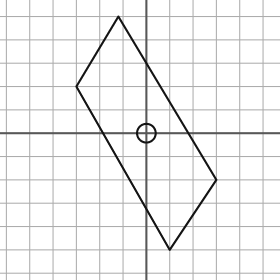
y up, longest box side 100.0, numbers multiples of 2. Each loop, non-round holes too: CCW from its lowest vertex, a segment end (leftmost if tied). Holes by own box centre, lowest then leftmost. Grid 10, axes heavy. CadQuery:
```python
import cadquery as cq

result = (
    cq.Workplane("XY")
    .moveTo(10.0, -50.0)
    .lineTo(30.0, -20.0)
    .lineTo(-12.0, 50.0)
    .lineTo(-30.0, 20.0)
    .close()
    .moveTo(0.0, 0.0)
    .circle(4.0)
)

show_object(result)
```